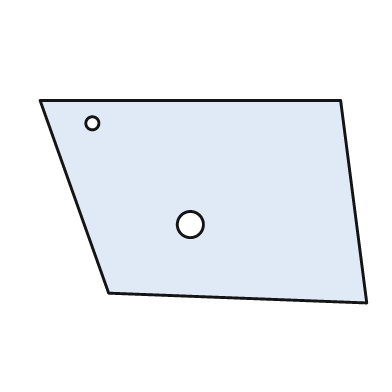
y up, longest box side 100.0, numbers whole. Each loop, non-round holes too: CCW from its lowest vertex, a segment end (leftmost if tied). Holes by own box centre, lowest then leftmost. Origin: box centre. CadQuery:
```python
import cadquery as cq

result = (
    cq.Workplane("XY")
    .moveTo(50.0, -31.0)
    .lineTo(42.0, 31.0)
    .lineTo(-50.0, 31.0)
    .lineTo(-29.0, -28.0)
    .close()
    .moveTo(-4.0, -7.0)
    .circle(4.0)
    .moveTo(-34.0, 24.0)
    .circle(2.0)
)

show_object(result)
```